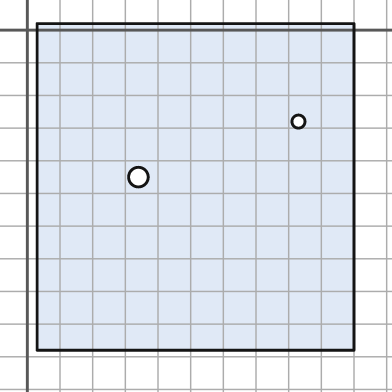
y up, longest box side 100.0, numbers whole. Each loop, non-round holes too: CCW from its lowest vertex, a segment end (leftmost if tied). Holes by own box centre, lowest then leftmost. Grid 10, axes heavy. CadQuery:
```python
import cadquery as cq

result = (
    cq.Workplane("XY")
    .moveTo(3.0, -98.0)
    .lineTo(100.0, -98.0)
    .lineTo(100.0, 2.0)
    .lineTo(3.0, 2.0)
    .close()
    .moveTo(34.0, -45.0)
    .circle(3.0)
    .moveTo(83.0, -28.0)
    .circle(2.0)
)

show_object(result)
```